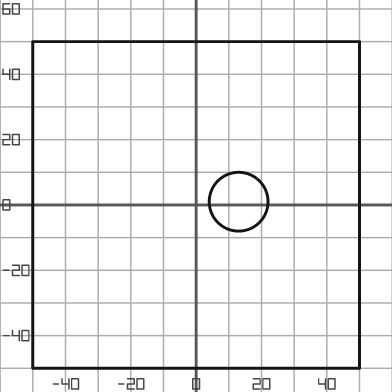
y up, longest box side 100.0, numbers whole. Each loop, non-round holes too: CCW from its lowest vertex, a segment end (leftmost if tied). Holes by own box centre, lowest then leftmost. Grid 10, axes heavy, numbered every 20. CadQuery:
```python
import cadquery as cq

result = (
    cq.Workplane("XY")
    .moveTo(-50.0, -50.0)
    .lineTo(50.0, -50.0)
    .lineTo(50.0, 50.0)
    .lineTo(-50.0, 50.0)
    .close()
    .moveTo(13.0, 1.0)
    .circle(9.0)
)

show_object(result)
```